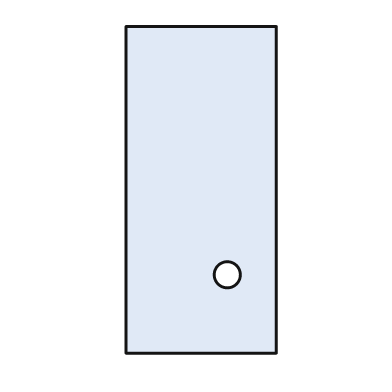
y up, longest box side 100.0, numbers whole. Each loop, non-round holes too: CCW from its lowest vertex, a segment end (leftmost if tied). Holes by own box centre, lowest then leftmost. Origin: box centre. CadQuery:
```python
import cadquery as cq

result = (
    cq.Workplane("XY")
    .moveTo(-23.0, -50.0)
    .lineTo(23.0, -50.0)
    .lineTo(23.0, 50.0)
    .lineTo(-23.0, 50.0)
    .close()
    .moveTo(8.0, -26.0)
    .circle(4.0)
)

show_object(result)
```